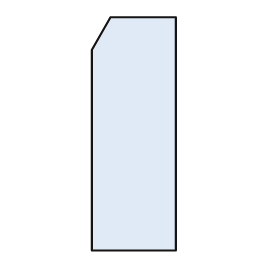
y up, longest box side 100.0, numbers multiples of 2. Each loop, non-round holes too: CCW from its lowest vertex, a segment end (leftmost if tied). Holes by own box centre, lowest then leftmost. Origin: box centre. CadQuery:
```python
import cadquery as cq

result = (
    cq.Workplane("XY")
    .moveTo(-18.0, -50.0)
    .lineTo(18.0, -50.0)
    .lineTo(18.0, 50.0)
    .lineTo(-10.0, 50.0)
    .lineTo(-18.0, 36.0)
    .close()
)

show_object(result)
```